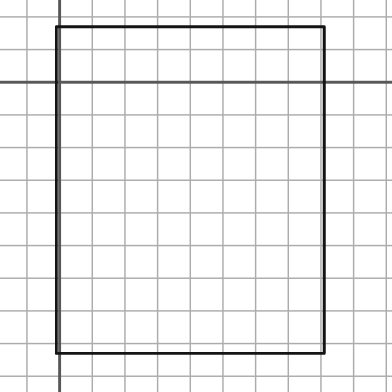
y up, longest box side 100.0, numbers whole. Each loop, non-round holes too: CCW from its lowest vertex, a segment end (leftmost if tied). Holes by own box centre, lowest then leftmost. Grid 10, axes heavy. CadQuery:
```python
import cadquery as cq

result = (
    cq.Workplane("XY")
    .moveTo(-1.0, -83.0)
    .lineTo(81.0, -83.0)
    .lineTo(81.0, 17.0)
    .lineTo(-1.0, 17.0)
    .close()
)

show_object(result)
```